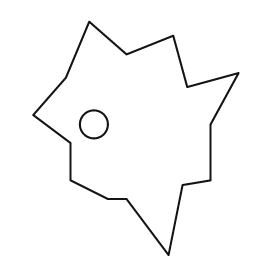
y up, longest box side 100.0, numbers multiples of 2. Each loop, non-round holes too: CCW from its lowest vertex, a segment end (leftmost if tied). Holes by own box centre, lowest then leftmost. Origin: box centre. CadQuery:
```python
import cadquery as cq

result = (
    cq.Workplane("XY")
    .moveTo(14.0, -50.0)
    .lineTo(20.0, -20.0)
    .lineTo(32.0, -18.0)
    .lineTo(32.0, 6.0)
    .lineTo(44.0, 28.0)
    .lineTo(22.0, 22.0)
    .lineTo(16.0, 44.0)
    .lineTo(-4.0, 36.0)
    .lineTo(-20.0, 50.0)
    .lineTo(-30.0, 26.0)
    .lineTo(-44.0, 10.0)
    .lineTo(-28.0, -2.0)
    .lineTo(-28.0, -18.0)
    .lineTo(-12.0, -26.0)
    .lineTo(-4.0, -26.0)
    .close()
    .moveTo(-18.0, 6.0)
    .circle(6.0)
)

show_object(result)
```